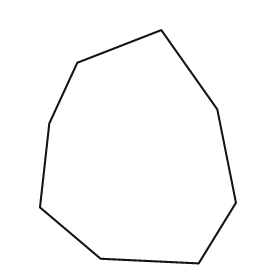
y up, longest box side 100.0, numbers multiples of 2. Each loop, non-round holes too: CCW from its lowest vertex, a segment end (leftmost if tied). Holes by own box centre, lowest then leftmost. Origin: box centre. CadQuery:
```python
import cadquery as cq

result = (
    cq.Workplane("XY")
    .moveTo(26.0, -50.0)
    .lineTo(42.0, -24.0)
    .lineTo(34.0, 16.0)
    .lineTo(10.0, 50.0)
    .lineTo(-26.0, 36.0)
    .lineTo(-38.0, 10.0)
    .lineTo(-42.0, -26.0)
    .lineTo(-16.0, -48.0)
    .close()
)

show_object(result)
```